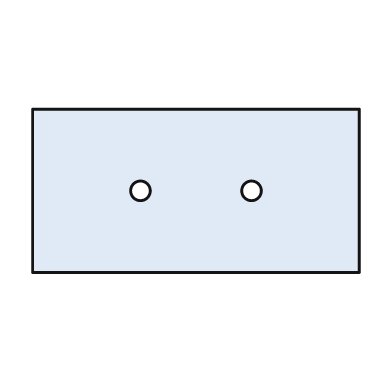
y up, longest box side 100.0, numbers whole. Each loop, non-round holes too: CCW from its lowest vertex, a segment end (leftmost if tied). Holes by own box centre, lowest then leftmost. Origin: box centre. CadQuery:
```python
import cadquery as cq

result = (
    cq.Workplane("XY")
    .moveTo(-50.0, -25.0)
    .lineTo(50.0, -25.0)
    .lineTo(50.0, 25.0)
    .lineTo(-50.0, 25.0)
    .close()
    .moveTo(-17.0, 0.0)
    .circle(3.0)
    .moveTo(17.0, 0.0)
    .circle(3.0)
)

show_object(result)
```